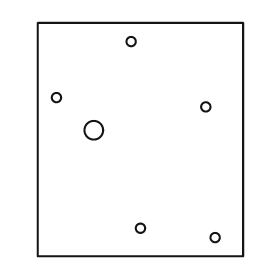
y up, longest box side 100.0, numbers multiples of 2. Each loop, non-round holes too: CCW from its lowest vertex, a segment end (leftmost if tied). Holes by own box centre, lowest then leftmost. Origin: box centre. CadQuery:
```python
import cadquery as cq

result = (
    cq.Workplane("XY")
    .moveTo(-44.0, -50.0)
    .lineTo(44.0, -50.0)
    .lineTo(44.0, 50.0)
    .lineTo(-44.0, 50.0)
    .close()
    .moveTo(32.0, -42.0)
    .circle(2.0)
    .moveTo(0.0, -38.0)
    .circle(2.0)
    .moveTo(-20.0, 4.0)
    .circle(4.0)
    .moveTo(28.0, 14.0)
    .circle(2.0)
    .moveTo(-36.0, 18.0)
    .circle(2.0)
    .moveTo(-4.0, 42.0)
    .circle(2.0)
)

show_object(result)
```